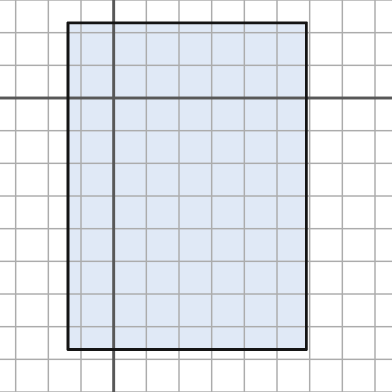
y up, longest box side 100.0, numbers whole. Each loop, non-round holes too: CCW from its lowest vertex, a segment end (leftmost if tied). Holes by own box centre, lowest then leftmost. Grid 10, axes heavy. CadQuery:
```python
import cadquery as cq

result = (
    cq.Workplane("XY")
    .moveTo(-14.0, -77.0)
    .lineTo(59.0, -77.0)
    .lineTo(59.0, 23.0)
    .lineTo(-14.0, 23.0)
    .close()
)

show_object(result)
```